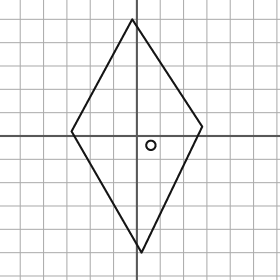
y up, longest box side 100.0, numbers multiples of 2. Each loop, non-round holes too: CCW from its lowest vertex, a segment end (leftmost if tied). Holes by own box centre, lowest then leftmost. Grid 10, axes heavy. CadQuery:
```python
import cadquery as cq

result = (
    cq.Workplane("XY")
    .moveTo(2.0, -50.0)
    .lineTo(28.0, 4.0)
    .lineTo(-2.0, 50.0)
    .lineTo(-28.0, 2.0)
    .close()
    .moveTo(6.0, -4.0)
    .circle(2.0)
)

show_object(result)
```